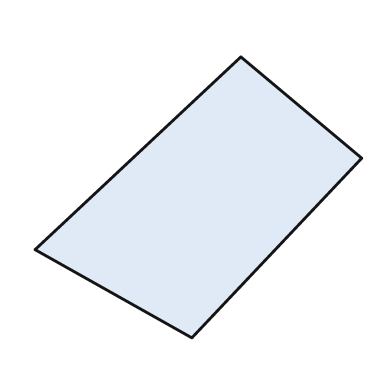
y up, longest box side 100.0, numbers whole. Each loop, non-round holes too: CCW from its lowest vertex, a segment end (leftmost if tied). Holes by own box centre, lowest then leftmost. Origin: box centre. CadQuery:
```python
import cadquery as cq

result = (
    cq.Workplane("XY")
    .moveTo(-2.0, -43.0)
    .lineTo(50.0, 12.0)
    .lineTo(13.0, 43.0)
    .lineTo(-50.0, -16.0)
    .close()
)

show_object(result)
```